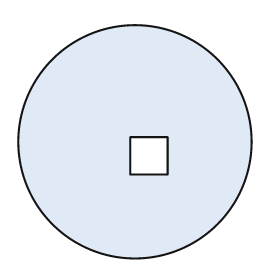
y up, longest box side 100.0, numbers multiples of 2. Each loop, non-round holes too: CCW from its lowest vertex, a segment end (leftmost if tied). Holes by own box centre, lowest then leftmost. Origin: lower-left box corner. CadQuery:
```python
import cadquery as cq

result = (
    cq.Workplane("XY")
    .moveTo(50.0, 50.0)
    .circle(50.0)
    .moveTo(48.0, 36.0)
    .lineTo(64.0, 36.0)
    .lineTo(64.0, 52.0)
    .lineTo(48.0, 52.0)
    .close()
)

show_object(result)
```